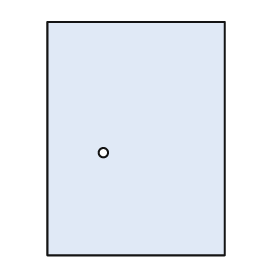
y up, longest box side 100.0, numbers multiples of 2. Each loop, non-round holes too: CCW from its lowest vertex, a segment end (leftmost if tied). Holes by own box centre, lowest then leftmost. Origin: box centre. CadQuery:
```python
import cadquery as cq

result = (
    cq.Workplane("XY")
    .moveTo(-38.0, -50.0)
    .lineTo(38.0, -50.0)
    .lineTo(38.0, 50.0)
    .lineTo(-38.0, 50.0)
    .close()
    .moveTo(-14.0, -6.0)
    .circle(2.0)
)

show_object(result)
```